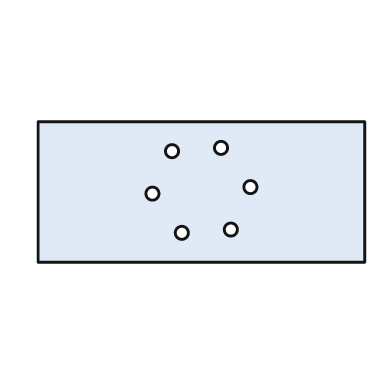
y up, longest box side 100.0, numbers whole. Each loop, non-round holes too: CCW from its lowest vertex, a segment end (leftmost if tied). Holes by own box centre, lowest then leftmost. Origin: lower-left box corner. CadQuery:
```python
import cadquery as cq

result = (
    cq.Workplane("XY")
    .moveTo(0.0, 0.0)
    .lineTo(100.0, 0.0)
    .lineTo(100.0, 43.0)
    .lineTo(0.0, 43.0)
    .close()
    .moveTo(44.0, 9.0)
    .circle(2.0)
    .moveTo(59.0, 10.0)
    .circle(2.0)
    .moveTo(35.0, 21.0)
    .circle(2.0)
    .moveTo(65.0, 23.0)
    .circle(2.0)
    .moveTo(41.0, 34.0)
    .circle(2.0)
    .moveTo(56.0, 35.0)
    .circle(2.0)
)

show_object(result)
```